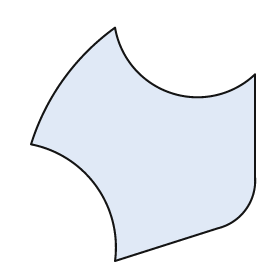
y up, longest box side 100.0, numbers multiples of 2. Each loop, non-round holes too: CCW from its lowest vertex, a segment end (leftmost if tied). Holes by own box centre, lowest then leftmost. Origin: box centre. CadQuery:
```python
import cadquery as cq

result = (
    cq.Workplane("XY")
    .moveTo(-12.0, -50.0)
    .lineTo(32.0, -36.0)
    .threePointArc((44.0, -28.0), (48.0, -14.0))
    .lineTo(48.0, 30.0)
    .threePointArc((12.0, 22.0), (-12.0, 50.0))
    .threePointArc((-34.0, 28.0), (-48.0, 0.0))
    .threePointArc((-20.0, -18.0), (-12.0, -50.0))
    .close()
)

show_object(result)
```